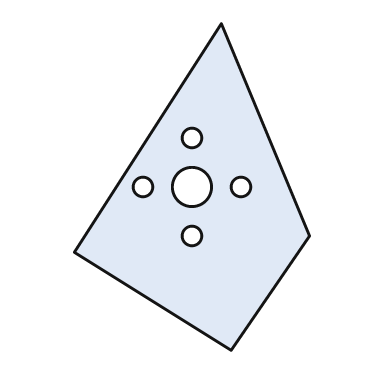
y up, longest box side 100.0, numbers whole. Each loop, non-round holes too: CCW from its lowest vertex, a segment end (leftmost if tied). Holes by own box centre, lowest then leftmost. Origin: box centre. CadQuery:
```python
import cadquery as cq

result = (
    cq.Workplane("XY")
    .moveTo(12.0, -50.0)
    .lineTo(36.0, -15.0)
    .lineTo(9.0, 50.0)
    .lineTo(-36.0, -20.0)
    .close()
    .moveTo(0.0, -15.0)
    .circle(3.0)
    .moveTo(-15.0, 0.0)
    .circle(3.0)
    .moveTo(0.0, 0.0)
    .circle(6.0)
    .moveTo(15.0, 0.0)
    .circle(3.0)
    .moveTo(0.0, 15.0)
    .circle(3.0)
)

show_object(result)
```